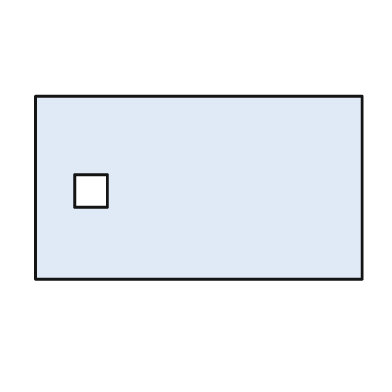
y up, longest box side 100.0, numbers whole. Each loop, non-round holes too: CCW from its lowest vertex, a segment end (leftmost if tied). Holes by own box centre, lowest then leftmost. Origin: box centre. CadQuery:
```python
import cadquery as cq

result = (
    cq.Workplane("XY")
    .moveTo(-50.0, -28.0)
    .lineTo(50.0, -28.0)
    .lineTo(50.0, 28.0)
    .lineTo(-50.0, 28.0)
    .close()
    .moveTo(-38.0, -6.0)
    .lineTo(-28.0, -6.0)
    .lineTo(-28.0, 4.0)
    .lineTo(-38.0, 4.0)
    .close()
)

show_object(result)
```